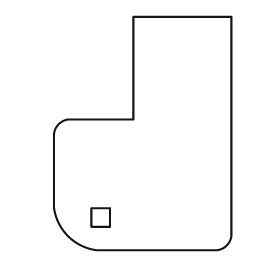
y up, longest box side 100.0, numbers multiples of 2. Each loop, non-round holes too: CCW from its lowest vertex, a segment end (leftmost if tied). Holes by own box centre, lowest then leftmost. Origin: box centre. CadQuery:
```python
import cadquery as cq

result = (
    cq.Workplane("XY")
    .moveTo(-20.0, -50.0)
    .lineTo(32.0, -50.0)
    .threePointArc((36.0, -48.0), (38.0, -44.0))
    .lineTo(38.0, 50.0)
    .lineTo(-4.0, 50.0)
    .lineTo(-4.0, 6.0)
    .lineTo(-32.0, 6.0)
    .threePointArc((-36.0, 4.0), (-38.0, 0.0))
    .lineTo(-38.0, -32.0)
    .threePointArc((-32.0, -44.0), (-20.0, -50.0))
    .close()
    .moveTo(-22.0, -40.0)
    .lineTo(-14.0, -40.0)
    .lineTo(-14.0, -32.0)
    .lineTo(-22.0, -32.0)
    .close()
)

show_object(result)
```